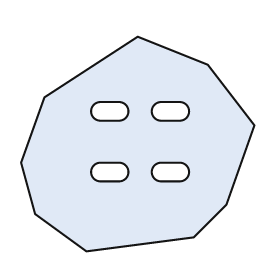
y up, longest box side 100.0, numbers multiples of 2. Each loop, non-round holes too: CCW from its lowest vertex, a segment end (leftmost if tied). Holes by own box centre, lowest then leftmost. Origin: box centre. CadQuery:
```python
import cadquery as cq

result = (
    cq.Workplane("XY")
    .moveTo(-22.0, -46.0)
    .lineTo(24.0, -40.0)
    .lineTo(38.0, -26.0)
    .lineTo(50.0, 8.0)
    .lineTo(30.0, 34.0)
    .lineTo(0.0, 46.0)
    .lineTo(-40.0, 20.0)
    .lineTo(-50.0, -8.0)
    .lineTo(-44.0, -30.0)
    .close()
    .moveTo(-16.0, -16.0)
    .lineTo(-8.0, -16.0)
    .threePointArc((-4.0, -12.0), (-8.0, -8.0))
    .lineTo(-16.0, -8.0)
    .threePointArc((-20.0, -12.0), (-16.0, -16.0))
    .close()
    .moveTo(10.0, -16.0)
    .lineTo(18.0, -16.0)
    .threePointArc((22.0, -12.0), (18.0, -8.0))
    .lineTo(10.0, -8.0)
    .threePointArc((6.0, -12.0), (10.0, -16.0))
    .close()
    .moveTo(-16.0, 10.0)
    .lineTo(-8.0, 10.0)
    .threePointArc((-4.0, 14.0), (-8.0, 18.0))
    .lineTo(-16.0, 18.0)
    .threePointArc((-20.0, 14.0), (-16.0, 10.0))
    .close()
    .moveTo(10.0, 10.0)
    .lineTo(18.0, 10.0)
    .threePointArc((22.0, 14.0), (18.0, 18.0))
    .lineTo(10.0, 18.0)
    .threePointArc((6.0, 14.0), (10.0, 10.0))
    .close()
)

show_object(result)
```